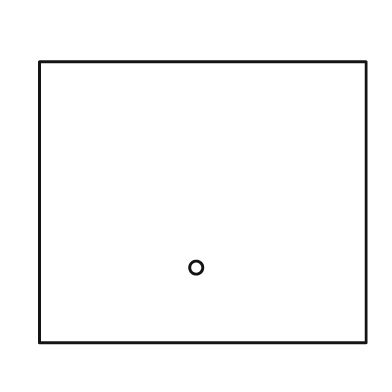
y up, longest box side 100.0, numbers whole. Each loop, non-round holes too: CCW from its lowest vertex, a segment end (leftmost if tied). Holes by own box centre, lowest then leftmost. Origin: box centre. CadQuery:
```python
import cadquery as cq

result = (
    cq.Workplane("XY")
    .moveTo(-50.0, -43.0)
    .lineTo(50.0, -43.0)
    .lineTo(50.0, 43.0)
    .lineTo(-50.0, 43.0)
    .close()
    .moveTo(-2.0, -20.0)
    .circle(2.0)
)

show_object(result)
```